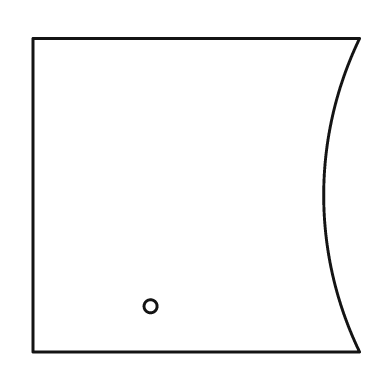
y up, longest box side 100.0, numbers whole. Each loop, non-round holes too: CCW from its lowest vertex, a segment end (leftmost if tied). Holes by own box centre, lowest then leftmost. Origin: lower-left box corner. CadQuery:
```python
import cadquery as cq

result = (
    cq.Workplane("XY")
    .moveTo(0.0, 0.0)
    .lineTo(100.0, 0.0)
    .threePointArc((89.0, 48.0), (100.0, 96.0))
    .lineTo(0.0, 96.0)
    .close()
    .moveTo(36.0, 14.0)
    .circle(2.0)
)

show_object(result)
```